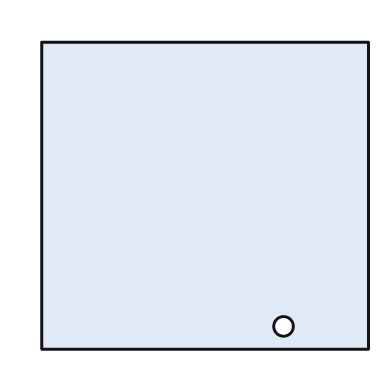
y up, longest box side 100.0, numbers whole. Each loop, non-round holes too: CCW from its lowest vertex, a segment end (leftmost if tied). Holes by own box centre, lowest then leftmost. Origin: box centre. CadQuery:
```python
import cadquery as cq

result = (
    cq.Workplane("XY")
    .moveTo(-50.0, -47.0)
    .lineTo(50.0, -47.0)
    .lineTo(50.0, 47.0)
    .lineTo(-50.0, 47.0)
    .close()
    .moveTo(24.0, -40.0)
    .circle(3.0)
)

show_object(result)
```